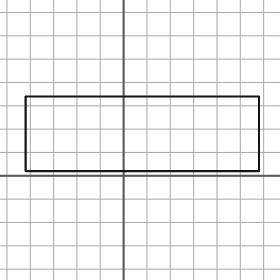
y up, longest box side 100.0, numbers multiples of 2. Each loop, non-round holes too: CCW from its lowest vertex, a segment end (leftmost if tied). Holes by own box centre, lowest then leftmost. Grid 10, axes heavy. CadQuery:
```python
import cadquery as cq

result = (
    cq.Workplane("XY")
    .moveTo(-42.0, 2.0)
    .lineTo(58.0, 2.0)
    .lineTo(58.0, 34.0)
    .lineTo(-42.0, 34.0)
    .close()
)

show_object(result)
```